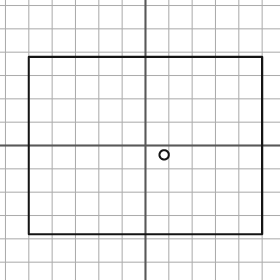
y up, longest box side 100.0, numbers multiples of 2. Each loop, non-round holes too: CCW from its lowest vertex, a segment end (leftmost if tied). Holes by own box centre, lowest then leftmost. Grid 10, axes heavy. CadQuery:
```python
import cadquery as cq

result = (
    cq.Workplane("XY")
    .moveTo(-50.0, -38.0)
    .lineTo(50.0, -38.0)
    .lineTo(50.0, 38.0)
    .lineTo(-50.0, 38.0)
    .close()
    .moveTo(8.0, -4.0)
    .circle(2.0)
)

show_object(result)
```